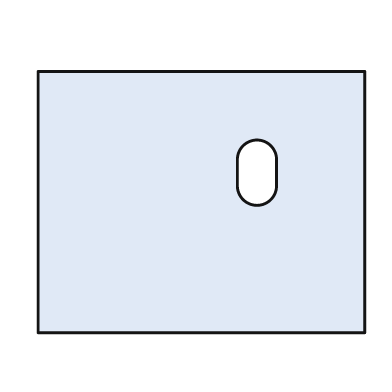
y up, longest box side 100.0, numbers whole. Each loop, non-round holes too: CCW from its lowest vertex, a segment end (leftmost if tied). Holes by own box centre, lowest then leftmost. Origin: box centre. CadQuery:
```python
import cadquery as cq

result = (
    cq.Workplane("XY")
    .moveTo(-50.0, -40.0)
    .lineTo(50.0, -40.0)
    .lineTo(50.0, 40.0)
    .lineTo(-50.0, 40.0)
    .close()
    .moveTo(11.0, 5.0)
    .threePointArc((17.0, -1.0), (23.0, 5.0))
    .lineTo(23.0, 13.0)
    .threePointArc((17.0, 19.0), (11.0, 13.0))
    .close()
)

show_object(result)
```